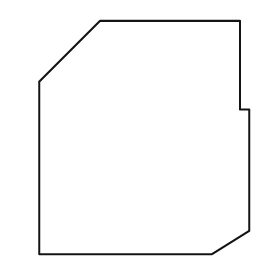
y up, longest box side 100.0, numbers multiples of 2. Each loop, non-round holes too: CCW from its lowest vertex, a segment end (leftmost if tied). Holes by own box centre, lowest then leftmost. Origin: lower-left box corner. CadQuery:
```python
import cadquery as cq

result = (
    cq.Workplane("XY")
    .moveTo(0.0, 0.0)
    .lineTo(74.0, 0.0)
    .lineTo(90.0, 10.0)
    .lineTo(90.0, 62.0)
    .lineTo(86.0, 62.0)
    .lineTo(86.0, 100.0)
    .lineTo(26.0, 100.0)
    .lineTo(0.0, 74.0)
    .close()
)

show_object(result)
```